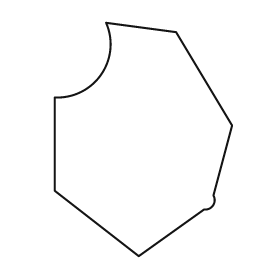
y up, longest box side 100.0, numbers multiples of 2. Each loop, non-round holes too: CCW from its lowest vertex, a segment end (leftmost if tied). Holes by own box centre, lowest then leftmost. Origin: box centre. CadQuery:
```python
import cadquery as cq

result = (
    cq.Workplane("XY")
    .moveTo(-2.0, -50.0)
    .lineTo(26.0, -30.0)
    .threePointArc((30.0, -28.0), (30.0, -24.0))
    .lineTo(38.0, 6.0)
    .lineTo(14.0, 46.0)
    .lineTo(-16.0, 50.0)
    .threePointArc((-18.0, 28.0), (-38.0, 18.0))
    .lineTo(-38.0, -22.0)
    .close()
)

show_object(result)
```